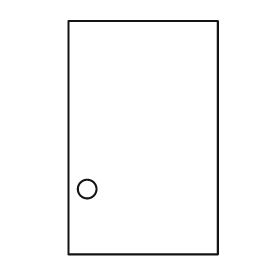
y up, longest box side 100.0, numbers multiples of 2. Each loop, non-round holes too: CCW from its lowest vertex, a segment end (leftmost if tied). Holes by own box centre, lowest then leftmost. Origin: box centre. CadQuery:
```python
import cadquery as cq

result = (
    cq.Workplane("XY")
    .moveTo(-32.0, -50.0)
    .lineTo(32.0, -50.0)
    .lineTo(32.0, 50.0)
    .lineTo(-32.0, 50.0)
    .close()
    .moveTo(-24.0, -22.0)
    .circle(4.0)
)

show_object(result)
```